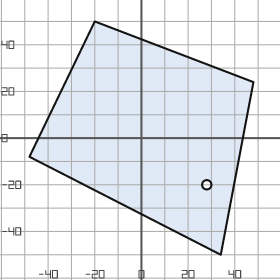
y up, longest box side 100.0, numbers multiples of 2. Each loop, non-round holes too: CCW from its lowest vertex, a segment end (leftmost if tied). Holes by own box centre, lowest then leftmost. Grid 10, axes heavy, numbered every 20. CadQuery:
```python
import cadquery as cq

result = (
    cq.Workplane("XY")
    .moveTo(34.0, -50.0)
    .lineTo(48.0, 24.0)
    .lineTo(-20.0, 50.0)
    .lineTo(-48.0, -8.0)
    .close()
    .moveTo(28.0, -20.0)
    .circle(2.0)
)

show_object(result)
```